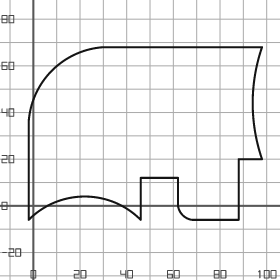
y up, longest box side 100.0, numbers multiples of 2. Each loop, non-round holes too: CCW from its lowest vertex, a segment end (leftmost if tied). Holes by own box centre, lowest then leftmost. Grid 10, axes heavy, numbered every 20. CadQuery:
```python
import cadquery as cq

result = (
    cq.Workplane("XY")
    .moveTo(-2.0, -6.0)
    .threePointArc((22.0, 4.0), (46.0, -6.0))
    .lineTo(46.0, 12.0)
    .lineTo(62.0, 12.0)
    .lineTo(62.0, 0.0)
    .threePointArc((64.0, -4.0), (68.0, -6.0))
    .lineTo(88.0, -6.0)
    .lineTo(88.0, 20.0)
    .lineTo(98.0, 20.0)
    .threePointArc((94.0, 44.0), (98.0, 68.0))
    .lineTo(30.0, 68.0)
    .threePointArc((8.0, 58.0), (-2.0, 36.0))
    .close()
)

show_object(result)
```